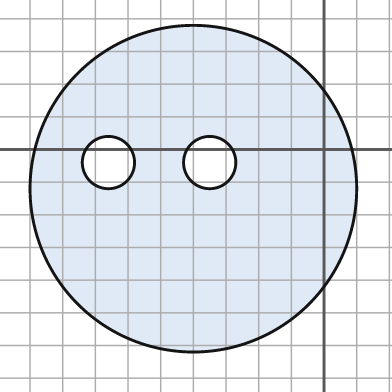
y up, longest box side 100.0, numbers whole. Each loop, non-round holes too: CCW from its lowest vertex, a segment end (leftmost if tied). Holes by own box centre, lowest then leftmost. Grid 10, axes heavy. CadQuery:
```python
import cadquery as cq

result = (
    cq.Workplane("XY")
    .moveTo(-40.0, -12.0)
    .circle(50.0)
    .moveTo(-66.0, -4.0)
    .circle(8.0)
    .moveTo(-35.0, -4.0)
    .circle(8.0)
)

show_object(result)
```